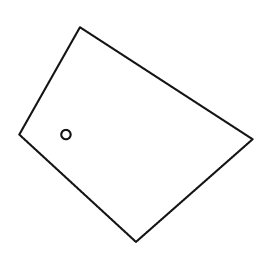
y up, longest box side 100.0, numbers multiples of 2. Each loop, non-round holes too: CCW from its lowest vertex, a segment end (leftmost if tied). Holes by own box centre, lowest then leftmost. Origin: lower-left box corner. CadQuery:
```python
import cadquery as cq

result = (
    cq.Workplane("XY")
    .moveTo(50.0, 0.0)
    .lineTo(100.0, 44.0)
    .lineTo(26.0, 92.0)
    .lineTo(0.0, 46.0)
    .close()
    .moveTo(20.0, 46.0)
    .circle(2.0)
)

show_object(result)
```